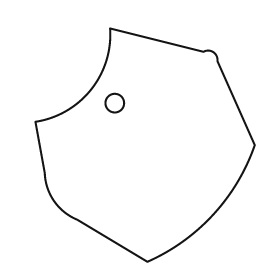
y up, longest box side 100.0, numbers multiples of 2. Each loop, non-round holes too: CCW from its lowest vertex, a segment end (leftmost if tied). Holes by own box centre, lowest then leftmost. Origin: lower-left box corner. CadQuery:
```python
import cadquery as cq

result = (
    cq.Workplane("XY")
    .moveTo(48.0, 0.0)
    .threePointArc((76.0, 20.0), (94.0, 50.0))
    .lineTo(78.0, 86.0)
    .threePointArc((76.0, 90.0), (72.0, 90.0))
    .lineTo(32.0, 100.0)
    .threePointArc((24.0, 74.0), (0.0, 60.0))
    .lineTo(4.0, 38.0)
    .threePointArc((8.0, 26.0), (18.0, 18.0))
    .close()
    .moveTo(34.0, 68.0)
    .circle(4.0)
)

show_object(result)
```